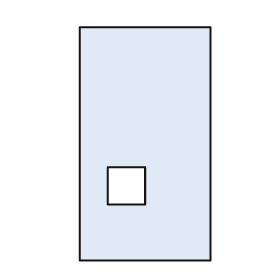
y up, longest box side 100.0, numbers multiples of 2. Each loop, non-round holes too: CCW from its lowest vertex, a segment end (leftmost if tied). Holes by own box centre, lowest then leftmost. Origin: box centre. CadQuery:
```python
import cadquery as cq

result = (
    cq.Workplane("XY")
    .moveTo(-28.0, -50.0)
    .lineTo(28.0, -50.0)
    .lineTo(28.0, 50.0)
    .lineTo(-28.0, 50.0)
    .close()
    .moveTo(-16.0, -26.0)
    .lineTo(0.0, -26.0)
    .lineTo(0.0, -10.0)
    .lineTo(-16.0, -10.0)
    .close()
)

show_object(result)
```